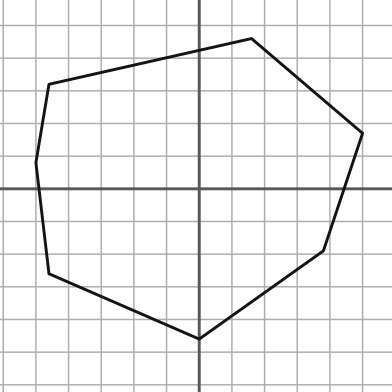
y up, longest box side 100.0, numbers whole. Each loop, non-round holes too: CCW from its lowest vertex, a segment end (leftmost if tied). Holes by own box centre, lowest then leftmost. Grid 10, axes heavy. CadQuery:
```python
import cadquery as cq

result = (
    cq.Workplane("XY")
    .moveTo(0.0, -46.0)
    .lineTo(38.0, -19.0)
    .lineTo(50.0, 17.0)
    .lineTo(16.0, 46.0)
    .lineTo(-46.0, 32.0)
    .lineTo(-50.0, 8.0)
    .lineTo(-46.0, -26.0)
    .close()
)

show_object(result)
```